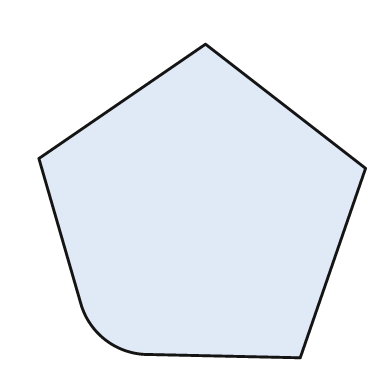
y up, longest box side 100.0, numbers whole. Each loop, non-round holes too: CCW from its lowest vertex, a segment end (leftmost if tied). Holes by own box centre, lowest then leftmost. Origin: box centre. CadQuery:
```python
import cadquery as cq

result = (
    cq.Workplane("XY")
    .moveTo(30.0, -48.0)
    .lineTo(50.0, 10.0)
    .lineTo(1.0, 48.0)
    .lineTo(-50.0, 13.0)
    .lineTo(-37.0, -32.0)
    .threePointArc((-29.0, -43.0), (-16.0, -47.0))
    .close()
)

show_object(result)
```